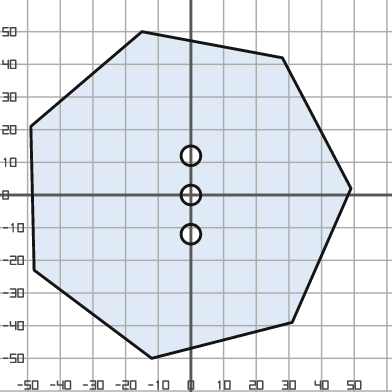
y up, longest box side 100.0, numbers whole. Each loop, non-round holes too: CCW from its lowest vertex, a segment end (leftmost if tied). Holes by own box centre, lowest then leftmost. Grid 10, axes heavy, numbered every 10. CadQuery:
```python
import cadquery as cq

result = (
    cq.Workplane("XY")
    .moveTo(-12.0, -50.0)
    .lineTo(31.0, -39.0)
    .lineTo(49.0, 2.0)
    .lineTo(28.0, 42.0)
    .lineTo(-15.0, 50.0)
    .lineTo(-49.0, 21.0)
    .lineTo(-48.0, -23.0)
    .close()
    .moveTo(0.0, -12.0)
    .circle(3.0)
    .moveTo(0.0, 0.0)
    .circle(3.0)
    .moveTo(0.0, 12.0)
    .circle(3.0)
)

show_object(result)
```